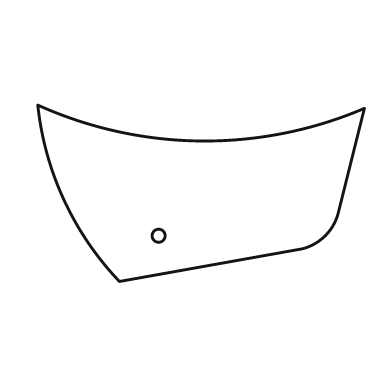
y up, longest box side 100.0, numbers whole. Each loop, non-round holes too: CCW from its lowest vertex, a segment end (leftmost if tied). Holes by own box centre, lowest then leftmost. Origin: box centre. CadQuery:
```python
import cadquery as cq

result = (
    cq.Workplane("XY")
    .moveTo(-25.0, -27.0)
    .lineTo(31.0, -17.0)
    .threePointArc((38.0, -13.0), (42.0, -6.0))
    .lineTo(50.0, 26.0)
    .threePointArc((0.0, 16.0), (-50.0, 27.0))
    .threePointArc((-42.0, -2.0), (-25.0, -27.0))
    .close()
    .moveTo(-13.0, -13.0)
    .circle(2.0)
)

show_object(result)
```